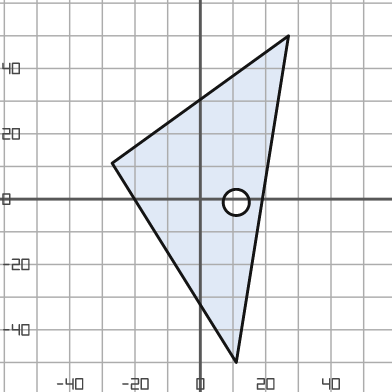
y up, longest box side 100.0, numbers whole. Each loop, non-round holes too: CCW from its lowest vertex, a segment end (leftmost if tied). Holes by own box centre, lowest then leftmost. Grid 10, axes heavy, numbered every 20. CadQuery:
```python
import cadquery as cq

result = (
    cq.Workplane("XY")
    .moveTo(11.0, -50.0)
    .lineTo(27.0, 50.0)
    .lineTo(-27.0, 11.0)
    .close()
    .moveTo(11.0, -1.0)
    .circle(4.0)
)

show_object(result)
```